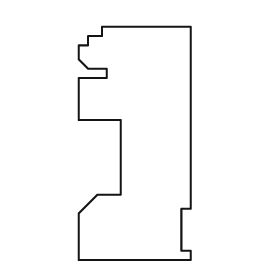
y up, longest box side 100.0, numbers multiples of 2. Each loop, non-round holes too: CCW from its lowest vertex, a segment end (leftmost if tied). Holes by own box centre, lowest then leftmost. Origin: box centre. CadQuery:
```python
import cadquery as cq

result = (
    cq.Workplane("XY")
    .moveTo(-24.0, -50.0)
    .lineTo(24.0, -50.0)
    .lineTo(24.0, -46.0)
    .lineTo(20.0, -46.0)
    .lineTo(20.0, -28.0)
    .lineTo(24.0, -28.0)
    .lineTo(24.0, 50.0)
    .lineTo(-14.0, 50.0)
    .lineTo(-14.0, 46.0)
    .lineTo(-20.0, 46.0)
    .lineTo(-20.0, 42.0)
    .lineTo(-24.0, 42.0)
    .lineTo(-24.0, 36.0)
    .lineTo(-20.0, 32.0)
    .lineTo(-12.0, 32.0)
    .lineTo(-12.0, 28.0)
    .lineTo(-24.0, 28.0)
    .lineTo(-24.0, 10.0)
    .lineTo(-6.0, 10.0)
    .lineTo(-6.0, -22.0)
    .lineTo(-16.0, -22.0)
    .lineTo(-24.0, -30.0)
    .close()
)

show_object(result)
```